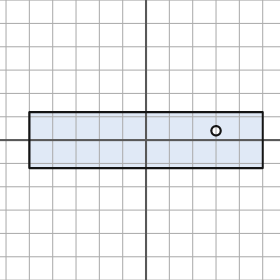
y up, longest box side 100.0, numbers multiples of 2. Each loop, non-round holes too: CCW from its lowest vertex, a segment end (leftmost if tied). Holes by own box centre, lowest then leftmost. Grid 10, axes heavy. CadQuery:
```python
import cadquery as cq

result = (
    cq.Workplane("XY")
    .moveTo(-50.0, -12.0)
    .lineTo(50.0, -12.0)
    .lineTo(50.0, 12.0)
    .lineTo(-50.0, 12.0)
    .close()
    .moveTo(30.0, 4.0)
    .circle(2.0)
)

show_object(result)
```